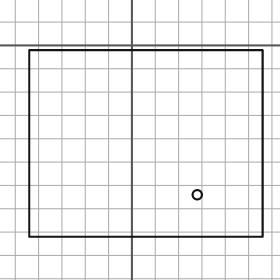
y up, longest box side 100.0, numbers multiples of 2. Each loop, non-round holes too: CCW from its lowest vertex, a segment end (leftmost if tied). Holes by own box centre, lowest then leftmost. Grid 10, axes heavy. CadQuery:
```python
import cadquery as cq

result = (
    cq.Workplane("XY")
    .moveTo(-44.0, -82.0)
    .lineTo(56.0, -82.0)
    .lineTo(56.0, -2.0)
    .lineTo(-44.0, -2.0)
    .close()
    .moveTo(28.0, -64.0)
    .circle(2.0)
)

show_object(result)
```